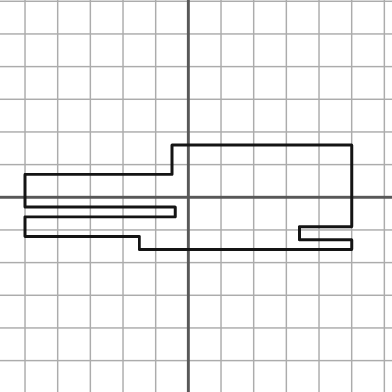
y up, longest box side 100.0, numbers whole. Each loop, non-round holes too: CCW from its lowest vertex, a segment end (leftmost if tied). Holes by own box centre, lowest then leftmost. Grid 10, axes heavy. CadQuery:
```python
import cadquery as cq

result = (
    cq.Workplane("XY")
    .moveTo(-15.0, -16.0)
    .lineTo(50.0, -16.0)
    .lineTo(50.0, -13.0)
    .lineTo(34.0, -13.0)
    .lineTo(34.0, -9.0)
    .lineTo(50.0, -9.0)
    .lineTo(50.0, 16.0)
    .lineTo(-5.0, 16.0)
    .lineTo(-5.0, 7.0)
    .lineTo(-50.0, 7.0)
    .lineTo(-50.0, -3.0)
    .lineTo(-4.0, -3.0)
    .lineTo(-4.0, -6.0)
    .lineTo(-50.0, -6.0)
    .lineTo(-50.0, -12.0)
    .lineTo(-15.0, -12.0)
    .close()
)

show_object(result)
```